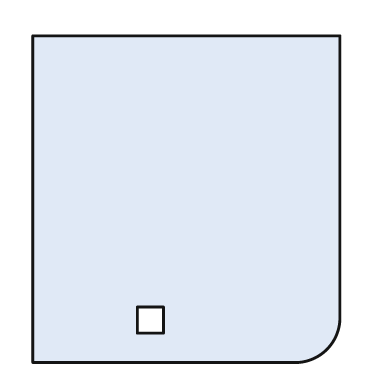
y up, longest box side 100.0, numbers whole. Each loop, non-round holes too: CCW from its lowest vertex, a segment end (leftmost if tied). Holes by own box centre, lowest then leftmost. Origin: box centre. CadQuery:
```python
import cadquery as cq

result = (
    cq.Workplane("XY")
    .moveTo(-47.0, -50.0)
    .lineTo(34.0, -50.0)
    .threePointArc((43.0, -46.0), (47.0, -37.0))
    .lineTo(47.0, 50.0)
    .lineTo(-47.0, 50.0)
    .close()
    .moveTo(-15.0, -41.0)
    .lineTo(-7.0, -41.0)
    .lineTo(-7.0, -33.0)
    .lineTo(-15.0, -33.0)
    .close()
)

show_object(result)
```